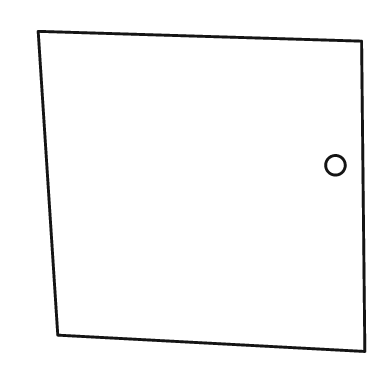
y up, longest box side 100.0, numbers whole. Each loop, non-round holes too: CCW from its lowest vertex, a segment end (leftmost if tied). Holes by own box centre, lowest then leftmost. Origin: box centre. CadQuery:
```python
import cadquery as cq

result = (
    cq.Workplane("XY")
    .moveTo(50.0, -49.0)
    .lineTo(49.0, 46.0)
    .lineTo(-50.0, 49.0)
    .lineTo(-44.0, -44.0)
    .close()
    .moveTo(41.0, 8.0)
    .circle(3.0)
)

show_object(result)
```